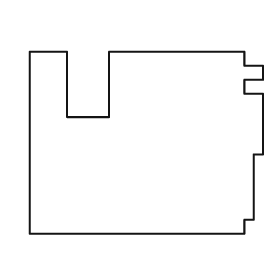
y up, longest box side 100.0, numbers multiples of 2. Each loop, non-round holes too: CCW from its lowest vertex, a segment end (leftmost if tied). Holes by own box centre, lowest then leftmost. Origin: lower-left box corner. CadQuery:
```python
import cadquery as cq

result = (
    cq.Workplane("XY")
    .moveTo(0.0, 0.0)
    .lineTo(92.0, 0.0)
    .lineTo(92.0, 6.0)
    .lineTo(96.0, 6.0)
    .lineTo(96.0, 34.0)
    .lineTo(100.0, 34.0)
    .lineTo(100.0, 60.0)
    .lineTo(92.0, 60.0)
    .lineTo(92.0, 66.0)
    .lineTo(100.0, 66.0)
    .lineTo(100.0, 72.0)
    .lineTo(92.0, 72.0)
    .lineTo(92.0, 78.0)
    .lineTo(34.0, 78.0)
    .lineTo(34.0, 50.0)
    .lineTo(16.0, 50.0)
    .lineTo(16.0, 78.0)
    .lineTo(0.0, 78.0)
    .close()
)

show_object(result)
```